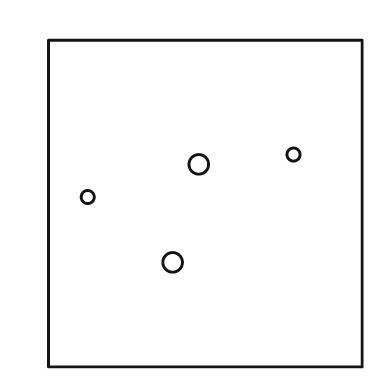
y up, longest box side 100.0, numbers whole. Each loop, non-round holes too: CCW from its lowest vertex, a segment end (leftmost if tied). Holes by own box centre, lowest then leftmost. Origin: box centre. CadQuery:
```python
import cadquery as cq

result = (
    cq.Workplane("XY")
    .moveTo(-48.0, -50.0)
    .lineTo(48.0, -50.0)
    .lineTo(48.0, 50.0)
    .lineTo(-48.0, 50.0)
    .close()
    .moveTo(-10.0, -18.0)
    .circle(3.0)
    .moveTo(-36.0, 2.0)
    .circle(2.0)
    .moveTo(-2.0, 12.0)
    .circle(3.0)
    .moveTo(27.0, 15.0)
    .circle(2.0)
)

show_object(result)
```